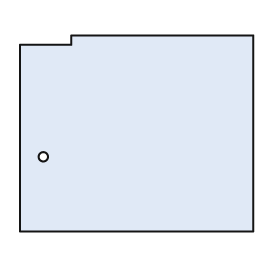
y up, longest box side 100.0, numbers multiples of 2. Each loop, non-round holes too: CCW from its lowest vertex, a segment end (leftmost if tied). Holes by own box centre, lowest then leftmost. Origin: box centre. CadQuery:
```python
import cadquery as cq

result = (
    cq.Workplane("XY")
    .moveTo(-50.0, -42.0)
    .lineTo(50.0, -42.0)
    .lineTo(50.0, 42.0)
    .lineTo(-28.0, 42.0)
    .lineTo(-28.0, 38.0)
    .lineTo(-50.0, 38.0)
    .close()
    .moveTo(-40.0, -10.0)
    .circle(2.0)
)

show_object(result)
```